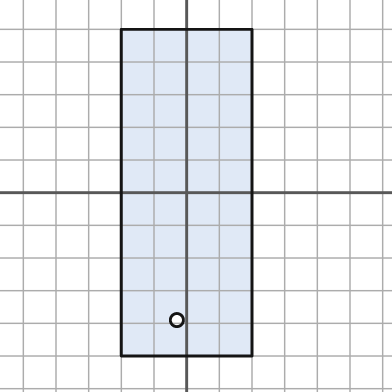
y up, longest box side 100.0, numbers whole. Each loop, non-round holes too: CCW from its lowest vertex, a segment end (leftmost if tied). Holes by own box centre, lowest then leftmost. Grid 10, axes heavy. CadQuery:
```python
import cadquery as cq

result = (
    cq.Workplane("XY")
    .moveTo(-20.0, -50.0)
    .lineTo(20.0, -50.0)
    .lineTo(20.0, 50.0)
    .lineTo(-20.0, 50.0)
    .close()
    .moveTo(-3.0, -39.0)
    .circle(2.0)
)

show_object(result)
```